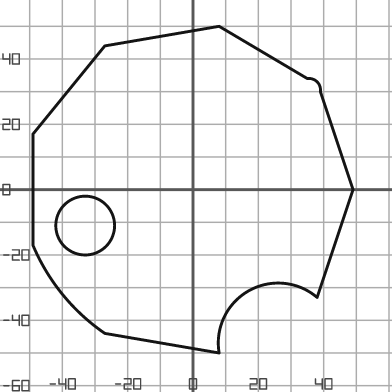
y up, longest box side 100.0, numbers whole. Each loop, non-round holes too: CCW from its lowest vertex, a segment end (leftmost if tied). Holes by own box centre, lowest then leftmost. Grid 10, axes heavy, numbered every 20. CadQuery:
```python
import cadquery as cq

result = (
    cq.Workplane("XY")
    .moveTo(8.0, -50.0)
    .threePointArc((17.0, -31.0), (38.0, -33.0))
    .lineTo(49.0, 0.0)
    .lineTo(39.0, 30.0)
    .threePointArc((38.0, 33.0), (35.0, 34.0))
    .lineTo(8.0, 50.0)
    .lineTo(-27.0, 44.0)
    .lineTo(-49.0, 17.0)
    .lineTo(-49.0, -17.0)
    .threePointArc((-40.0, -32.0), (-27.0, -44.0))
    .close()
    .moveTo(-33.0, -11.0)
    .circle(9.0)
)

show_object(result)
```